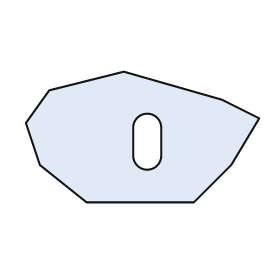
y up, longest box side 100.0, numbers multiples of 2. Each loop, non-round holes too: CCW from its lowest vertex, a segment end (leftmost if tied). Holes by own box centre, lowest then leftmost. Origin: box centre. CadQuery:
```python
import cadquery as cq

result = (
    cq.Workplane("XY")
    .moveTo(-24.0, -28.0)
    .lineTo(22.0, -28.0)
    .lineTo(38.0, -12.0)
    .lineTo(50.0, 8.0)
    .lineTo(34.0, 16.0)
    .lineTo(-8.0, 28.0)
    .lineTo(-40.0, 20.0)
    .lineTo(-50.0, 6.0)
    .lineTo(-44.0, -12.0)
    .close()
    .moveTo(-4.0, -8.0)
    .threePointArc((2.0, -14.0), (8.0, -8.0))
    .lineTo(8.0, 4.0)
    .threePointArc((2.0, 10.0), (-4.0, 4.0))
    .close()
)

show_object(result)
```